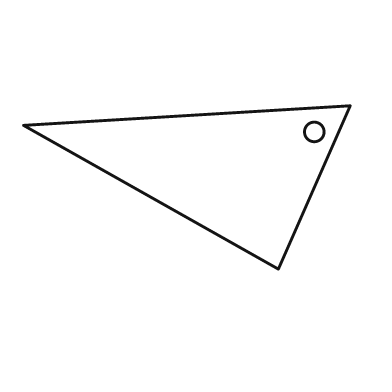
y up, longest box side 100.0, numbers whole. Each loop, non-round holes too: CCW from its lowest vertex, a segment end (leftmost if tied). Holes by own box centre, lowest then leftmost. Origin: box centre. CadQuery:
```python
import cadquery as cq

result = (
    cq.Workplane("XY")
    .moveTo(28.0, -25.0)
    .lineTo(50.0, 25.0)
    .lineTo(-50.0, 19.0)
    .close()
    .moveTo(39.0, 17.0)
    .circle(3.0)
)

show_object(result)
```